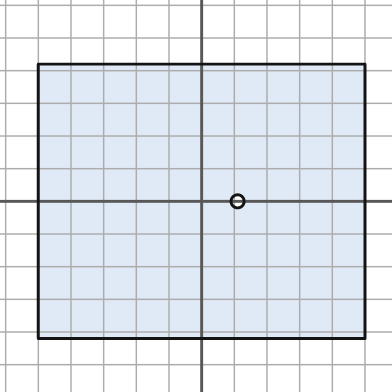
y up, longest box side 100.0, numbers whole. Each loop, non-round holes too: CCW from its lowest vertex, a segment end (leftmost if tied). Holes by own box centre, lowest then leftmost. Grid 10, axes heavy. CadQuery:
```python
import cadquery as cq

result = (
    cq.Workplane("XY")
    .moveTo(-50.0, -42.0)
    .lineTo(50.0, -42.0)
    .lineTo(50.0, 42.0)
    .lineTo(-50.0, 42.0)
    .close()
    .moveTo(11.0, 0.0)
    .circle(2.0)
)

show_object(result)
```